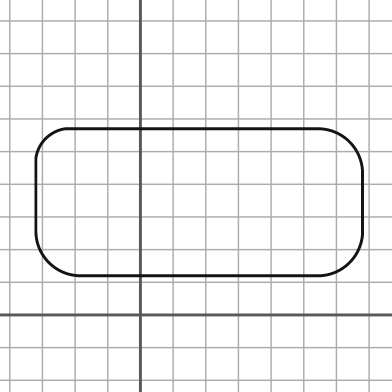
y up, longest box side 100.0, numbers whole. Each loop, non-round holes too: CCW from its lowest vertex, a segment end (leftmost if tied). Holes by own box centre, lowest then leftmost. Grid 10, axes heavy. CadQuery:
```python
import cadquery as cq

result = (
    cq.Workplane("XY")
    .moveTo(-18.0, 12.0)
    .lineTo(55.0, 12.0)
    .threePointArc((64.0, 16.0), (68.0, 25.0))
    .lineTo(68.0, 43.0)
    .threePointArc((64.0, 53.0), (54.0, 57.0))
    .lineTo(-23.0, 57.0)
    .threePointArc((-29.0, 54.0), (-32.0, 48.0))
    .lineTo(-32.0, 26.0)
    .threePointArc((-28.0, 16.0), (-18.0, 12.0))
    .close()
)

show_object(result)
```